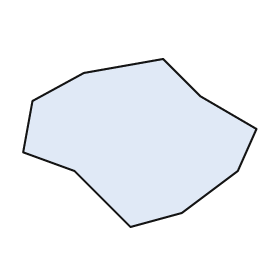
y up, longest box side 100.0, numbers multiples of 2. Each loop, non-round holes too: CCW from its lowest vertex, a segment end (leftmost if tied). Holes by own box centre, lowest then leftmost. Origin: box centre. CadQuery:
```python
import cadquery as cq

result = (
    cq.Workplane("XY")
    .moveTo(-4.0, -36.0)
    .lineTo(18.0, -30.0)
    .lineTo(42.0, -12.0)
    .lineTo(50.0, 6.0)
    .lineTo(26.0, 20.0)
    .lineTo(10.0, 36.0)
    .lineTo(-24.0, 30.0)
    .lineTo(-46.0, 18.0)
    .lineTo(-50.0, -4.0)
    .lineTo(-28.0, -12.0)
    .close()
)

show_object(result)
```